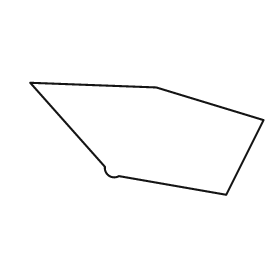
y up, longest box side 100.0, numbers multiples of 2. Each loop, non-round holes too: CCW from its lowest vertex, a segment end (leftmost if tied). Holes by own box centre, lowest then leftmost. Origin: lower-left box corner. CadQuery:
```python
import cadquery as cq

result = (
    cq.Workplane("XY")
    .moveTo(84.0, 0.0)
    .lineTo(100.0, 32.0)
    .lineTo(54.0, 46.0)
    .lineTo(0.0, 48.0)
    .lineTo(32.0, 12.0)
    .threePointArc((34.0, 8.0), (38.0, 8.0))
    .close()
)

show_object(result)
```